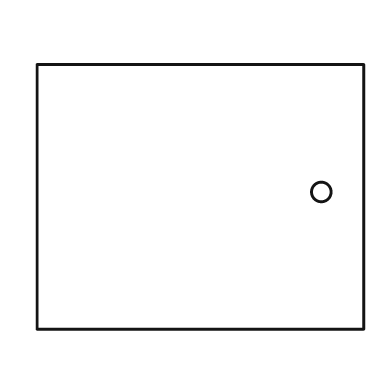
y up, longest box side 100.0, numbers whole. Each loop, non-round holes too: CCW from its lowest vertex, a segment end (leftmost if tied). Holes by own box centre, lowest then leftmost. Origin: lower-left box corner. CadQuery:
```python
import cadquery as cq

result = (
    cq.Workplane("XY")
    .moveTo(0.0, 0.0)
    .lineTo(100.0, 0.0)
    .lineTo(100.0, 81.0)
    .lineTo(0.0, 81.0)
    .close()
    .moveTo(87.0, 42.0)
    .circle(3.0)
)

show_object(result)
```